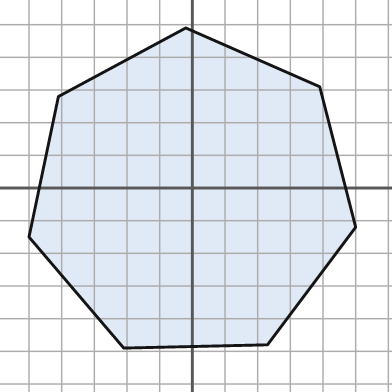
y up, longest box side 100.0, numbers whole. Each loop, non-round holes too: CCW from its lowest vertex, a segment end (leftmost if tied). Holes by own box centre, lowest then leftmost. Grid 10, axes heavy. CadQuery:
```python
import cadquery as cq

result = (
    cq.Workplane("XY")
    .moveTo(-21.0, -49.0)
    .lineTo(23.0, -48.0)
    .lineTo(50.0, -12.0)
    .lineTo(39.0, 31.0)
    .lineTo(-2.0, 49.0)
    .lineTo(-41.0, 28.0)
    .lineTo(-50.0, -15.0)
    .close()
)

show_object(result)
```